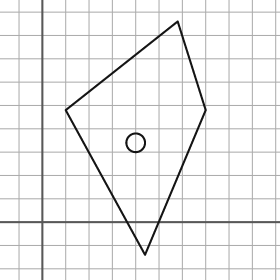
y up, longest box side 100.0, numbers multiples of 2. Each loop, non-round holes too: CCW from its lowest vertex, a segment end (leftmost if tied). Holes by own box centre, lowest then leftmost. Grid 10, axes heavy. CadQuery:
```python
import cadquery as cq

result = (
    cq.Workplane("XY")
    .moveTo(44.0, -14.0)
    .lineTo(70.0, 48.0)
    .lineTo(58.0, 86.0)
    .lineTo(10.0, 48.0)
    .close()
    .moveTo(40.0, 34.0)
    .circle(4.0)
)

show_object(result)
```